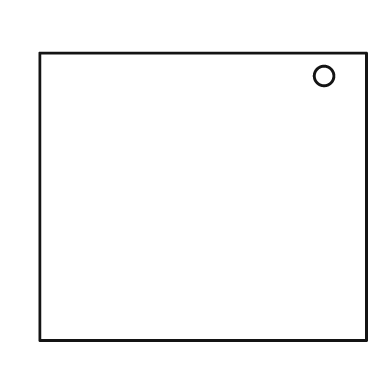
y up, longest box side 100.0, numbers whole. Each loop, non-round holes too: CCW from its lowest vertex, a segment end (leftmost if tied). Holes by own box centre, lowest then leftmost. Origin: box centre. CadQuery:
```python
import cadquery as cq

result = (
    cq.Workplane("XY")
    .moveTo(-50.0, -44.0)
    .lineTo(50.0, -44.0)
    .lineTo(50.0, 44.0)
    .lineTo(-50.0, 44.0)
    .close()
    .moveTo(37.0, 37.0)
    .circle(3.0)
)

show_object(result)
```